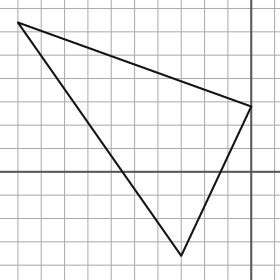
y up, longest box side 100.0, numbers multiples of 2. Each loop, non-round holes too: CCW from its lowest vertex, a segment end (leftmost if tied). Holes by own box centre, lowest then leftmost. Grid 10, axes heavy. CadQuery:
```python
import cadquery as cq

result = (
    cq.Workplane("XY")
    .moveTo(-30.0, -36.0)
    .lineTo(0.0, 28.0)
    .lineTo(-100.0, 64.0)
    .close()
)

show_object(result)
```